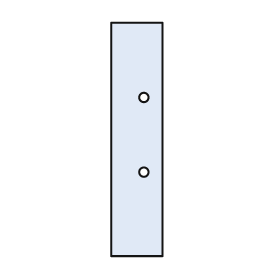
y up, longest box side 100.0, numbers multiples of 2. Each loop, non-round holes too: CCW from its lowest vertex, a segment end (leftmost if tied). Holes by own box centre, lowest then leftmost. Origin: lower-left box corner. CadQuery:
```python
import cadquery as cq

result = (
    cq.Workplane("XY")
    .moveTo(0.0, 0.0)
    .lineTo(22.0, 0.0)
    .lineTo(22.0, 100.0)
    .lineTo(0.0, 100.0)
    .close()
    .moveTo(14.0, 36.0)
    .circle(2.0)
    .moveTo(14.0, 68.0)
    .circle(2.0)
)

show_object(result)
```